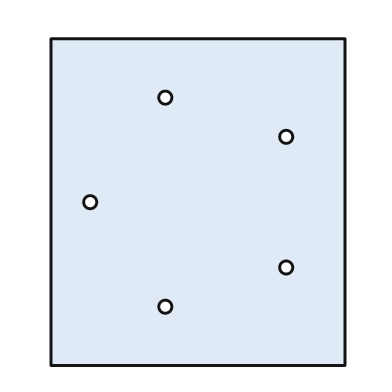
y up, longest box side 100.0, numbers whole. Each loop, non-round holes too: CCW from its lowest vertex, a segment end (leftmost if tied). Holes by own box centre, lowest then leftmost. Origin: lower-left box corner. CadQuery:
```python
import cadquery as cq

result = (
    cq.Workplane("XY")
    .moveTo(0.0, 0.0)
    .lineTo(90.0, 0.0)
    .lineTo(90.0, 100.0)
    .lineTo(0.0, 100.0)
    .close()
    .moveTo(35.0, 18.0)
    .circle(2.0)
    .moveTo(72.0, 30.0)
    .circle(2.0)
    .moveTo(12.0, 50.0)
    .circle(2.0)
    .moveTo(72.0, 70.0)
    .circle(2.0)
    .moveTo(35.0, 82.0)
    .circle(2.0)
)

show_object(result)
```